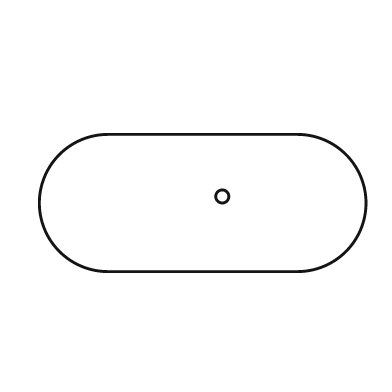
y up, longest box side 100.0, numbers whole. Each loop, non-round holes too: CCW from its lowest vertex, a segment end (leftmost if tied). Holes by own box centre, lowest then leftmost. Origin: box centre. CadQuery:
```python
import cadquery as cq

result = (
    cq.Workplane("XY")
    .moveTo(-29.0, -21.0)
    .lineTo(29.0, -21.0)
    .threePointArc((50.0, 0.0), (29.0, 21.0))
    .lineTo(-29.0, 21.0)
    .threePointArc((-50.0, 0.0), (-29.0, -21.0))
    .close()
    .moveTo(6.0, 2.0)
    .circle(2.0)
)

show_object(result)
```